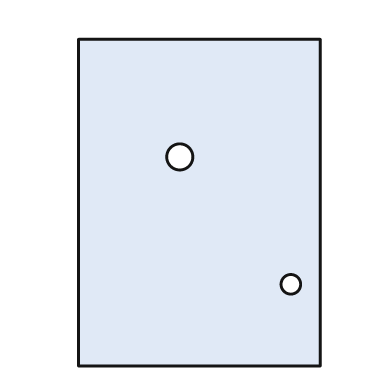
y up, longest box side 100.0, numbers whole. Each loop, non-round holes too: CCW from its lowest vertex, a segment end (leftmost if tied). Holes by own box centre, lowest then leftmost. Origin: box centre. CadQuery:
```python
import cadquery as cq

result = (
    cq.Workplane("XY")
    .moveTo(-37.0, -50.0)
    .lineTo(37.0, -50.0)
    .lineTo(37.0, 50.0)
    .lineTo(-37.0, 50.0)
    .close()
    .moveTo(28.0, -25.0)
    .circle(3.0)
    .moveTo(-6.0, 14.0)
    .circle(4.0)
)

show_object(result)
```